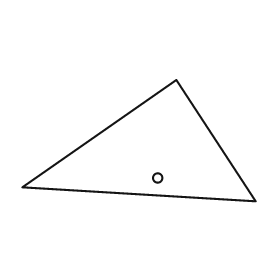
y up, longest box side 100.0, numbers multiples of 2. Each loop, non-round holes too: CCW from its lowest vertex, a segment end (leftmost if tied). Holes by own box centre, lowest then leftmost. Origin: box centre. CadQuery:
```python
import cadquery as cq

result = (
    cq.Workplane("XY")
    .moveTo(50.0, -26.0)
    .lineTo(16.0, 26.0)
    .lineTo(-50.0, -20.0)
    .close()
    .moveTo(8.0, -16.0)
    .circle(2.0)
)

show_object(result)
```